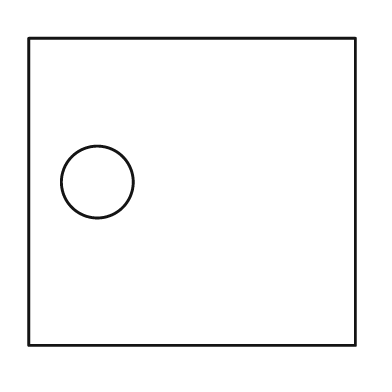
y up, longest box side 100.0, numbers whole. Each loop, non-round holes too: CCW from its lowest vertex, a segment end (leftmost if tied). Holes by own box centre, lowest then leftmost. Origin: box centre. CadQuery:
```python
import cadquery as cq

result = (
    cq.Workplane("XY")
    .moveTo(-50.0, -47.0)
    .lineTo(50.0, -47.0)
    .lineTo(50.0, 47.0)
    .lineTo(-50.0, 47.0)
    .close()
    .moveTo(-29.0, 3.0)
    .circle(11.0)
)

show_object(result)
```